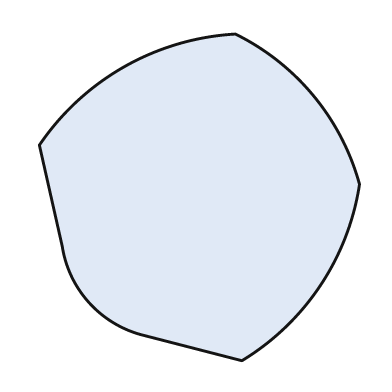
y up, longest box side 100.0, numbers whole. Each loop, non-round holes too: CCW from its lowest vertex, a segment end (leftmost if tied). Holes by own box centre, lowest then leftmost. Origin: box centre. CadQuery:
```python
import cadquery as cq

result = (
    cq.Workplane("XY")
    .moveTo(13.0, -50.0)
    .threePointArc((37.0, -27.0), (49.0, 4.0))
    .threePointArc((35.0, 31.0), (11.0, 50.0))
    .threePointArc((-23.0, 40.0), (-49.0, 16.0))
    .lineTo(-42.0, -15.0)
    .threePointArc((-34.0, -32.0), (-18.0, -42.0))
    .close()
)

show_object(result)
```